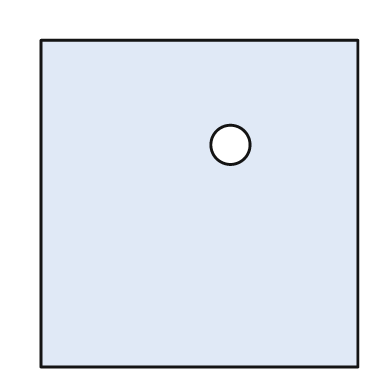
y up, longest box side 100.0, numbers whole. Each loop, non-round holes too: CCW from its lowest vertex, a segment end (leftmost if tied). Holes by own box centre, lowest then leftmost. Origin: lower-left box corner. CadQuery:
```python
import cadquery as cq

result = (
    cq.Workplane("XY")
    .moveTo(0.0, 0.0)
    .lineTo(97.0, 0.0)
    .lineTo(97.0, 100.0)
    .lineTo(0.0, 100.0)
    .close()
    .moveTo(58.0, 68.0)
    .circle(6.0)
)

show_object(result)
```